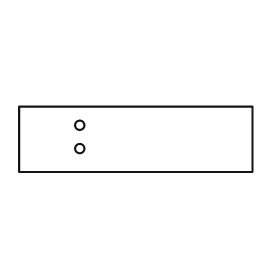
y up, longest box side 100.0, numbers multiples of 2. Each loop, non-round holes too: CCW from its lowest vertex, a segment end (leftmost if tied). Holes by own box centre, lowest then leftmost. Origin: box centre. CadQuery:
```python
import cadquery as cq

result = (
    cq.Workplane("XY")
    .moveTo(-50.0, -14.0)
    .lineTo(50.0, -14.0)
    .lineTo(50.0, 14.0)
    .lineTo(-50.0, 14.0)
    .close()
    .moveTo(-24.0, -4.0)
    .circle(2.0)
    .moveTo(-24.0, 6.0)
    .circle(2.0)
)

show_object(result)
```